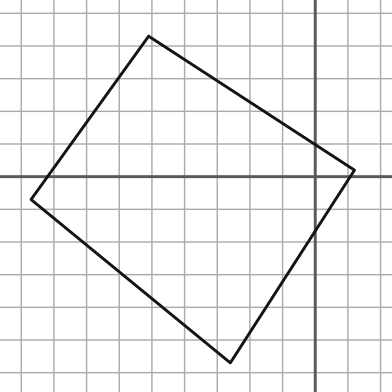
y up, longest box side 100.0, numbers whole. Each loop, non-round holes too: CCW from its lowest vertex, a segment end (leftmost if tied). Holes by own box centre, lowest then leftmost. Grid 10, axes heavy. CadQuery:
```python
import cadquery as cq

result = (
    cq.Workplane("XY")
    .moveTo(-26.0, -57.0)
    .lineTo(12.0, 2.0)
    .lineTo(-51.0, 43.0)
    .lineTo(-87.0, -7.0)
    .close()
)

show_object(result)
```